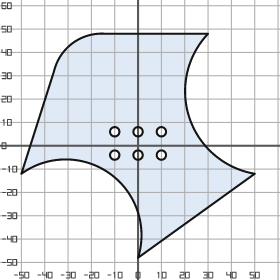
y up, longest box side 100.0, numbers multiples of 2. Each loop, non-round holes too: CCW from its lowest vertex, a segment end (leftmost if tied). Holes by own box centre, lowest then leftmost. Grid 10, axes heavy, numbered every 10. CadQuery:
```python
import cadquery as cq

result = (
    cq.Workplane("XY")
    .moveTo(0.0, -48.0)
    .lineTo(50.0, -12.0)
    .threePointArc((22.0, 12.0), (30.0, 48.0))
    .lineTo(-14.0, 48.0)
    .threePointArc((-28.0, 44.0), (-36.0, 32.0))
    .lineTo(-50.0, -12.0)
    .threePointArc((-12.0, -12.0), (0.0, -48.0))
    .close()
    .moveTo(-10.0, -4.0)
    .circle(2.0)
    .moveTo(0.0, -4.0)
    .circle(2.0)
    .moveTo(10.0, -4.0)
    .circle(2.0)
    .moveTo(-10.0, 6.0)
    .circle(2.0)
    .moveTo(0.0, 6.0)
    .circle(2.0)
    .moveTo(10.0, 6.0)
    .circle(2.0)
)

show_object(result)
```